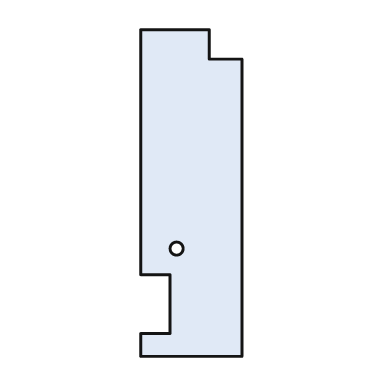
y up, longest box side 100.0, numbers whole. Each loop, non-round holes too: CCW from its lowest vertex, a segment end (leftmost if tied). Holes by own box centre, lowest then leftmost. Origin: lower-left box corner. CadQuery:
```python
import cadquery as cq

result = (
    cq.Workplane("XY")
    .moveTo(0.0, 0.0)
    .lineTo(31.0, 0.0)
    .lineTo(31.0, 91.0)
    .lineTo(21.0, 91.0)
    .lineTo(21.0, 100.0)
    .lineTo(0.0, 100.0)
    .lineTo(0.0, 25.0)
    .lineTo(9.0, 25.0)
    .lineTo(9.0, 7.0)
    .lineTo(0.0, 7.0)
    .close()
    .moveTo(11.0, 33.0)
    .circle(2.0)
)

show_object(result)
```